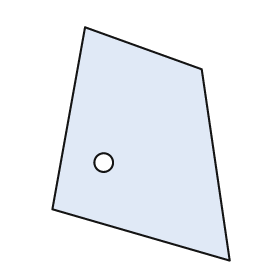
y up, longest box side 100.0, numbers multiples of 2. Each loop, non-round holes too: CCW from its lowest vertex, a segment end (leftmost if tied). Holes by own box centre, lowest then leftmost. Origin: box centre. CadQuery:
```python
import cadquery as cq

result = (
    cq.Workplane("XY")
    .moveTo(38.0, -50.0)
    .lineTo(26.0, 32.0)
    .lineTo(-24.0, 50.0)
    .lineTo(-38.0, -28.0)
    .close()
    .moveTo(-16.0, -8.0)
    .circle(4.0)
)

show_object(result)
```